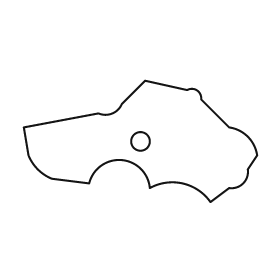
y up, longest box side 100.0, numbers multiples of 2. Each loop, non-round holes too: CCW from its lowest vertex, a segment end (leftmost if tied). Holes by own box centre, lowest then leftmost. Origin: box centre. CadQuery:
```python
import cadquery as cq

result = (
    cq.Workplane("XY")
    .moveTo(30.0, -26.0)
    .lineTo(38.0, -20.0)
    .threePointArc((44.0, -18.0), (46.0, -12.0))
    .lineTo(50.0, -6.0)
    .threePointArc((46.0, 2.0), (38.0, 6.0))
    .lineTo(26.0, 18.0)
    .threePointArc((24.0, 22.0), (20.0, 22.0))
    .lineTo(2.0, 26.0)
    .lineTo(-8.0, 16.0)
    .threePointArc((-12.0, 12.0), (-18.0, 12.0))
    .lineTo(-50.0, 6.0)
    .lineTo(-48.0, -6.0)
    .threePointArc((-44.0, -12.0), (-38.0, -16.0))
    .lineTo(-22.0, -18.0)
    .threePointArc((-8.0, -8.0), (4.0, -20.0))
    .threePointArc((18.0, -18.0), (30.0, -26.0))
    .close()
    .moveTo(0.0, 0.0)
    .circle(4.0)
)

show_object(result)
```